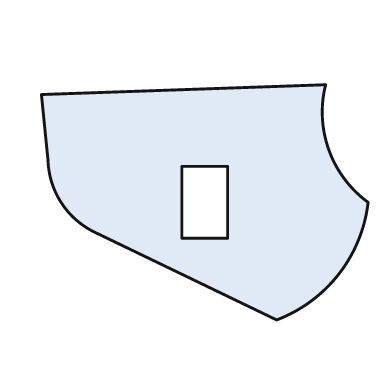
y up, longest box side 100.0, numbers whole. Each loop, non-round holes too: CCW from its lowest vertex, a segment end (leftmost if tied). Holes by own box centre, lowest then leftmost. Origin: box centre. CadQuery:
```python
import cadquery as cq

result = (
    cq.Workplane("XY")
    .moveTo(22.0, -36.0)
    .threePointArc((41.0, -22.0), (50.0, 0.0))
    .threePointArc((38.0, 16.0), (37.0, 36.0))
    .lineTo(-50.0, 33.0)
    .lineTo(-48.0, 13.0)
    .threePointArc((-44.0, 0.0), (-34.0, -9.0))
    .close()
    .moveTo(-7.0, -11.0)
    .lineTo(7.0, -11.0)
    .lineTo(7.0, 11.0)
    .lineTo(-7.0, 11.0)
    .close()
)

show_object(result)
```